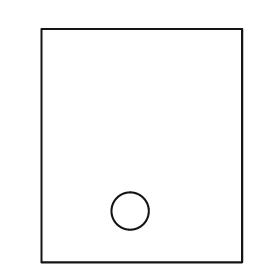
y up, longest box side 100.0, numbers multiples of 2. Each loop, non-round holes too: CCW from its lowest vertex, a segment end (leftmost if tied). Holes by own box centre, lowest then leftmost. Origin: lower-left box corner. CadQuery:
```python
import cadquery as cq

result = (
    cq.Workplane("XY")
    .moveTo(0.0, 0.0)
    .lineTo(86.0, 0.0)
    .lineTo(86.0, 100.0)
    .lineTo(0.0, 100.0)
    .close()
    .moveTo(38.0, 22.0)
    .circle(8.0)
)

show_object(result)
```